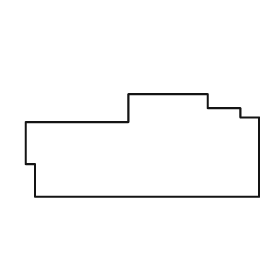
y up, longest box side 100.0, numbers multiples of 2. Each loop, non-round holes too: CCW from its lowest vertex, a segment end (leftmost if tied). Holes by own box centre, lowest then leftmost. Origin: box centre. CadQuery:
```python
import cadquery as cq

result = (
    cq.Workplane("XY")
    .moveTo(-46.0, -22.0)
    .lineTo(50.0, -22.0)
    .lineTo(50.0, 12.0)
    .lineTo(42.0, 12.0)
    .lineTo(42.0, 16.0)
    .lineTo(28.0, 16.0)
    .lineTo(28.0, 22.0)
    .lineTo(-6.0, 22.0)
    .lineTo(-6.0, 10.0)
    .lineTo(-50.0, 10.0)
    .lineTo(-50.0, -8.0)
    .lineTo(-46.0, -8.0)
    .close()
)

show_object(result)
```